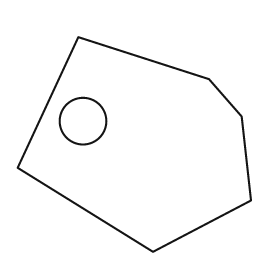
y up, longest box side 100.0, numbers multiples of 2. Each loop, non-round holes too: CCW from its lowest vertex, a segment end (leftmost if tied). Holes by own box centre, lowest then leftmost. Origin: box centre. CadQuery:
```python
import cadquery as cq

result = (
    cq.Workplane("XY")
    .moveTo(8.0, -46.0)
    .lineTo(50.0, -24.0)
    .lineTo(46.0, 12.0)
    .lineTo(32.0, 28.0)
    .lineTo(-24.0, 46.0)
    .lineTo(-50.0, -10.0)
    .close()
    .moveTo(-22.0, 10.0)
    .circle(10.0)
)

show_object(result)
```